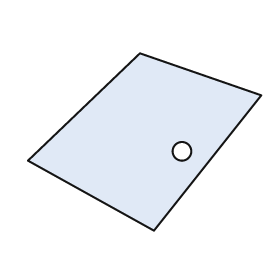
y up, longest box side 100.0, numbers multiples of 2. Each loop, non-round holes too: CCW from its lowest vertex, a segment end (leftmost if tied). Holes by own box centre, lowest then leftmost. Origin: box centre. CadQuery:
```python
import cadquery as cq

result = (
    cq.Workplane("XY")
    .moveTo(4.0, -38.0)
    .lineTo(50.0, 20.0)
    .lineTo(-2.0, 38.0)
    .lineTo(-50.0, -8.0)
    .close()
    .moveTo(16.0, -4.0)
    .circle(4.0)
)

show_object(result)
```